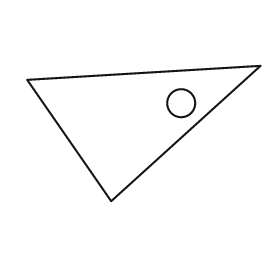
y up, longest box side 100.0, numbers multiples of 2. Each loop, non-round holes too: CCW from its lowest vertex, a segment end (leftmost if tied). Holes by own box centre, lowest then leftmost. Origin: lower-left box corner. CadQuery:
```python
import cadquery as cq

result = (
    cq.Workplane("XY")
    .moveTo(36.0, 0.0)
    .lineTo(100.0, 58.0)
    .lineTo(0.0, 52.0)
    .close()
    .moveTo(66.0, 42.0)
    .circle(6.0)
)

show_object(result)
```